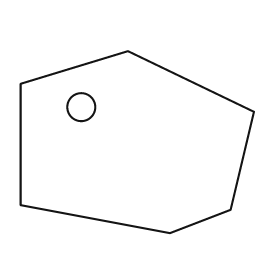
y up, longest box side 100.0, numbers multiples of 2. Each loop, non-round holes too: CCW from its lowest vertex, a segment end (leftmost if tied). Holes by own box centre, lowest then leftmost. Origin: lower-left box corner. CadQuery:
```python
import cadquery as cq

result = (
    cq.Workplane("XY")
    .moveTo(64.0, 0.0)
    .lineTo(90.0, 10.0)
    .lineTo(100.0, 52.0)
    .lineTo(46.0, 78.0)
    .lineTo(0.0, 64.0)
    .lineTo(0.0, 12.0)
    .close()
    .moveTo(26.0, 54.0)
    .circle(6.0)
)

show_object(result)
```